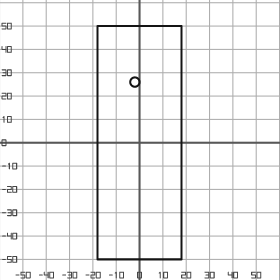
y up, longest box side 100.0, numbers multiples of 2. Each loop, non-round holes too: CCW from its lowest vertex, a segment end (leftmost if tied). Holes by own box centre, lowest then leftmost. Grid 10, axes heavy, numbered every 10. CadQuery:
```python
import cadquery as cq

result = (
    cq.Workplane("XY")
    .moveTo(-18.0, -50.0)
    .lineTo(18.0, -50.0)
    .lineTo(18.0, 50.0)
    .lineTo(-18.0, 50.0)
    .close()
    .moveTo(-2.0, 26.0)
    .circle(2.0)
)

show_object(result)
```